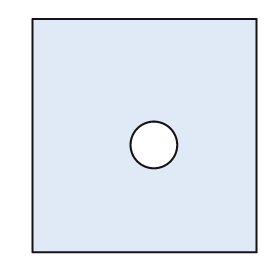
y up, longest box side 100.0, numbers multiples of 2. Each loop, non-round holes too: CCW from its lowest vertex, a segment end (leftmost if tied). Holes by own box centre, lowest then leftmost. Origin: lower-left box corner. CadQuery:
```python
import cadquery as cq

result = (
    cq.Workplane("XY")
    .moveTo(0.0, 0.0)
    .lineTo(96.0, 0.0)
    .lineTo(96.0, 100.0)
    .lineTo(0.0, 100.0)
    .close()
    .moveTo(52.0, 46.0)
    .circle(10.0)
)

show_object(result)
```